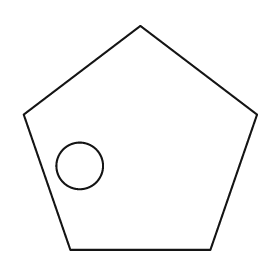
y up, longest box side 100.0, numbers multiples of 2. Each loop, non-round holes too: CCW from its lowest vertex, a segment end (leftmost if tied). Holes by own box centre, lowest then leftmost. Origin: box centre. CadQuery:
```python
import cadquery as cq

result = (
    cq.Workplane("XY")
    .moveTo(-30.0, -48.0)
    .lineTo(30.0, -48.0)
    .lineTo(50.0, 10.0)
    .lineTo(0.0, 48.0)
    .lineTo(-50.0, 10.0)
    .close()
    .moveTo(-26.0, -12.0)
    .circle(10.0)
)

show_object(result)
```